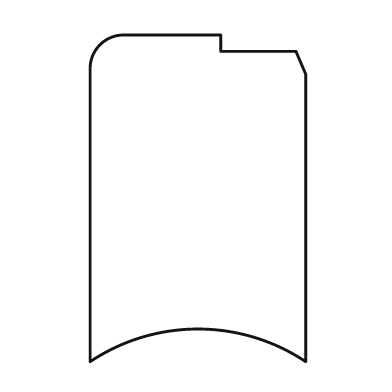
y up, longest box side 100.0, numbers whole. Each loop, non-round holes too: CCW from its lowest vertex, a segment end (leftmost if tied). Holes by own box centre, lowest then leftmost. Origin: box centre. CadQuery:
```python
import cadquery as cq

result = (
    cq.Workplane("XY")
    .moveTo(-33.0, -50.0)
    .threePointArc((0.0, -40.0), (33.0, -50.0))
    .lineTo(33.0, 38.0)
    .lineTo(30.0, 45.0)
    .lineTo(7.0, 45.0)
    .lineTo(7.0, 50.0)
    .lineTo(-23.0, 50.0)
    .threePointArc((-30.0, 47.0), (-33.0, 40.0))
    .close()
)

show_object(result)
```